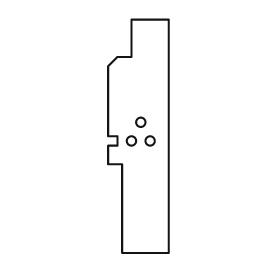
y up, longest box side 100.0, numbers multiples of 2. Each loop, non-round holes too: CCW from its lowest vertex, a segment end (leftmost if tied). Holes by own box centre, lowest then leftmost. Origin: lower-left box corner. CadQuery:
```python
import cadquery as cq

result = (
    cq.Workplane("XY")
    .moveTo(6.0, 0.0)
    .lineTo(26.0, 0.0)
    .lineTo(26.0, 100.0)
    .lineTo(10.0, 100.0)
    .lineTo(10.0, 84.0)
    .lineTo(4.0, 84.0)
    .lineTo(0.0, 80.0)
    .lineTo(0.0, 50.0)
    .lineTo(4.0, 50.0)
    .lineTo(4.0, 46.0)
    .lineTo(0.0, 46.0)
    .lineTo(0.0, 38.0)
    .lineTo(6.0, 38.0)
    .close()
    .moveTo(10.0, 48.0)
    .circle(2.0)
    .moveTo(18.0, 48.0)
    .circle(2.0)
    .moveTo(14.0, 56.0)
    .circle(2.0)
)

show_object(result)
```